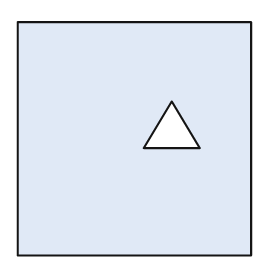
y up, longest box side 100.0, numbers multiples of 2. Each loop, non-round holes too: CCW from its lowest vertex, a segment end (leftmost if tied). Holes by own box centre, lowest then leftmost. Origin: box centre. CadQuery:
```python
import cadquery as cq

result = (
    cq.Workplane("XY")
    .moveTo(-50.0, -50.0)
    .lineTo(50.0, -50.0)
    .lineTo(50.0, 50.0)
    .lineTo(-50.0, 50.0)
    .close()
    .moveTo(4.0, -4.0)
    .lineTo(28.0, -4.0)
    .lineTo(16.0, 16.0)
    .close()
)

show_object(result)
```